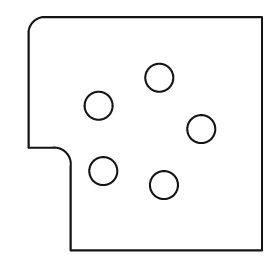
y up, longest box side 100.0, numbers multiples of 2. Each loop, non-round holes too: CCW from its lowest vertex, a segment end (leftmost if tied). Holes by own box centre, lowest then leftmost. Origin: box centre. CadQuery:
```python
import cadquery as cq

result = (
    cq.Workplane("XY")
    .moveTo(-32.0, -50.0)
    .lineTo(50.0, -50.0)
    .lineTo(50.0, 50.0)
    .lineTo(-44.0, 50.0)
    .threePointArc((-48.0, 48.0), (-50.0, 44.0))
    .lineTo(-50.0, -6.0)
    .lineTo(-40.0, -6.0)
    .threePointArc((-34.0, -8.0), (-32.0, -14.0))
    .close()
    .moveTo(8.0, -22.0)
    .circle(6.0)
    .moveTo(-18.0, -16.0)
    .circle(6.0)
    .moveTo(24.0, 2.0)
    .circle(6.0)
    .moveTo(-20.0, 12.0)
    .circle(6.0)
    .moveTo(6.0, 24.0)
    .circle(6.0)
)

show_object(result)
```